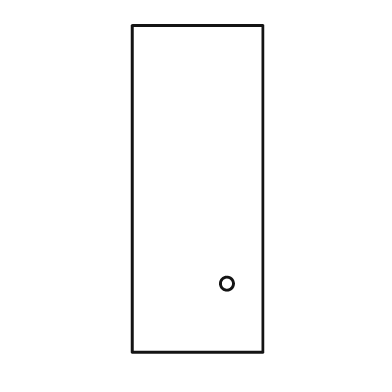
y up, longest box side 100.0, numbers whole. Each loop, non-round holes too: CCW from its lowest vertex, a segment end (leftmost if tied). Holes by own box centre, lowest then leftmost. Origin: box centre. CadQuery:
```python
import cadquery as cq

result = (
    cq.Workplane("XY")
    .moveTo(-20.0, -50.0)
    .lineTo(20.0, -50.0)
    .lineTo(20.0, 50.0)
    .lineTo(-20.0, 50.0)
    .close()
    .moveTo(9.0, -29.0)
    .circle(2.0)
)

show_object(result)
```